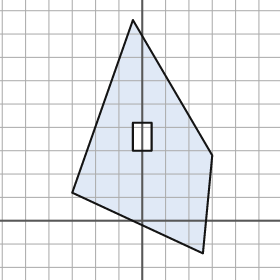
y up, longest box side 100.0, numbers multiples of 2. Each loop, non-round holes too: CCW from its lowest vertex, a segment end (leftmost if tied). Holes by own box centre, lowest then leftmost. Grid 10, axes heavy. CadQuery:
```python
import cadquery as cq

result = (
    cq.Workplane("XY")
    .moveTo(26.0, -14.0)
    .lineTo(30.0, 28.0)
    .lineTo(-4.0, 86.0)
    .lineTo(-30.0, 12.0)
    .close()
    .moveTo(-4.0, 30.0)
    .lineTo(4.0, 30.0)
    .lineTo(4.0, 42.0)
    .lineTo(-4.0, 42.0)
    .close()
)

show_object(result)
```